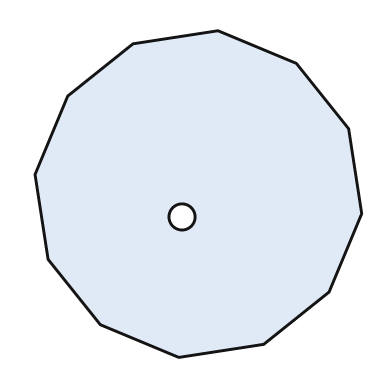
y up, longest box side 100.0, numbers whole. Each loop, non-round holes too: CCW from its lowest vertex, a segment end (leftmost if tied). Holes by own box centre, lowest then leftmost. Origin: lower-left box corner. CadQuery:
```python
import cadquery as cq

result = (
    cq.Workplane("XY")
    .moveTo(44.0, 0.0)
    .lineTo(70.0, 4.0)
    .lineTo(90.0, 20.0)
    .lineTo(100.0, 44.0)
    .lineTo(96.0, 70.0)
    .lineTo(80.0, 90.0)
    .lineTo(56.0, 100.0)
    .lineTo(30.0, 96.0)
    .lineTo(10.0, 80.0)
    .lineTo(0.0, 56.0)
    .lineTo(4.0, 30.0)
    .lineTo(20.0, 10.0)
    .close()
    .moveTo(45.0, 43.0)
    .circle(4.0)
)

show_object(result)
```